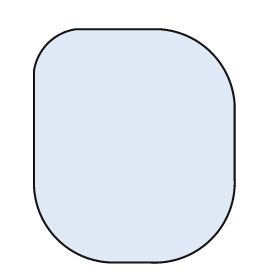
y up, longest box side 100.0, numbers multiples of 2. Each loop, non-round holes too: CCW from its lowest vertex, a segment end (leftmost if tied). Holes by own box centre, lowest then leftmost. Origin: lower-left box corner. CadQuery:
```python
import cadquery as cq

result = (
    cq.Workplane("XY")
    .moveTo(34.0, 0.0)
    .lineTo(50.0, 0.0)
    .threePointArc((76.0, 10.0), (86.0, 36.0))
    .lineTo(86.0, 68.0)
    .threePointArc((76.0, 90.0), (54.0, 100.0))
    .lineTo(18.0, 100.0)
    .threePointArc((6.0, 94.0), (0.0, 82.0))
    .lineTo(0.0, 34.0)
    .threePointArc((10.0, 10.0), (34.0, 0.0))
    .close()
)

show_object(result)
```